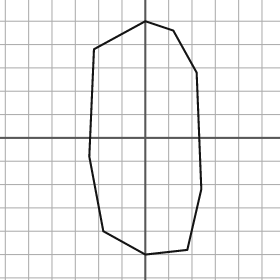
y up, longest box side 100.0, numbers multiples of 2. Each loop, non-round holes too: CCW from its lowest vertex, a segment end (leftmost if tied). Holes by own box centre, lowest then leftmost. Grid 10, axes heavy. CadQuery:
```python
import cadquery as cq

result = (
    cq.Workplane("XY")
    .moveTo(0.0, -50.0)
    .lineTo(18.0, -48.0)
    .lineTo(24.0, -22.0)
    .lineTo(22.0, 28.0)
    .lineTo(12.0, 46.0)
    .lineTo(0.0, 50.0)
    .lineTo(-22.0, 38.0)
    .lineTo(-24.0, -8.0)
    .lineTo(-18.0, -40.0)
    .close()
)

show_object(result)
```